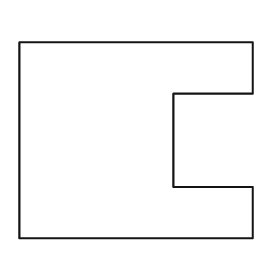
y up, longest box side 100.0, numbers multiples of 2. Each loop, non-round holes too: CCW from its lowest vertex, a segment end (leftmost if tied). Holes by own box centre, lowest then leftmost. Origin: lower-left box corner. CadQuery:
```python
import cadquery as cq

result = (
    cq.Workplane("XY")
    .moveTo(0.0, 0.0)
    .lineTo(100.0, 0.0)
    .lineTo(100.0, 22.0)
    .lineTo(66.0, 22.0)
    .lineTo(66.0, 62.0)
    .lineTo(100.0, 62.0)
    .lineTo(100.0, 84.0)
    .lineTo(0.0, 84.0)
    .close()
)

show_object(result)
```